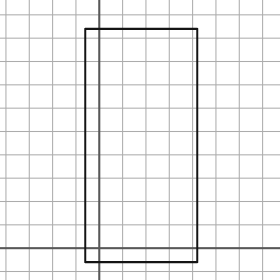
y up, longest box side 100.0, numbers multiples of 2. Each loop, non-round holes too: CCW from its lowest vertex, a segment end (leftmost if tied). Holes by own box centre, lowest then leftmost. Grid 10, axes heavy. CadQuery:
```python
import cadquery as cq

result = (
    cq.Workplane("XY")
    .moveTo(-6.0, -6.0)
    .lineTo(42.0, -6.0)
    .lineTo(42.0, 94.0)
    .lineTo(-6.0, 94.0)
    .close()
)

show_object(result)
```